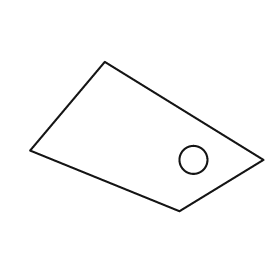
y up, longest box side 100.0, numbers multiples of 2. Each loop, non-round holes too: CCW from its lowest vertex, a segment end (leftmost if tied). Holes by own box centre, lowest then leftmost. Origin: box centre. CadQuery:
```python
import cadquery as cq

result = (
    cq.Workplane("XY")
    .moveTo(14.0, -32.0)
    .lineTo(50.0, -10.0)
    .lineTo(-18.0, 32.0)
    .lineTo(-50.0, -6.0)
    .close()
    .moveTo(20.0, -10.0)
    .circle(6.0)
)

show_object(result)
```